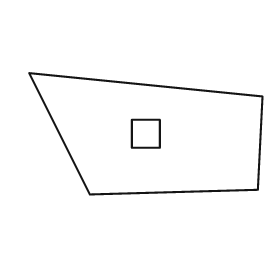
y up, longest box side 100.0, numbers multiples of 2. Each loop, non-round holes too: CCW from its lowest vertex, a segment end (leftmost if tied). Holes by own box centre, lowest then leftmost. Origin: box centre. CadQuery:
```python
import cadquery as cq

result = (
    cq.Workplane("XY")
    .moveTo(-24.0, -26.0)
    .lineTo(48.0, -24.0)
    .lineTo(50.0, 16.0)
    .lineTo(-50.0, 26.0)
    .close()
    .moveTo(-6.0, -6.0)
    .lineTo(6.0, -6.0)
    .lineTo(6.0, 6.0)
    .lineTo(-6.0, 6.0)
    .close()
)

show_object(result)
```